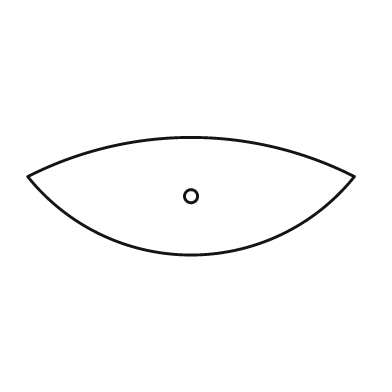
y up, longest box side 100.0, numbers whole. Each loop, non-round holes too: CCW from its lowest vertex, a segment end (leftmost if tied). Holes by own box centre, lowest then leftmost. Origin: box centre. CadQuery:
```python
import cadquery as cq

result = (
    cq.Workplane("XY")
    .moveTo(-50.0, 6.0)
    .threePointArc((0.0, -18.0), (50.0, 6.0))
    .threePointArc((0.0, 18.0), (-50.0, 6.0))
    .close()
    .moveTo(0.0, 0.0)
    .circle(2.0)
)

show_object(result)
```